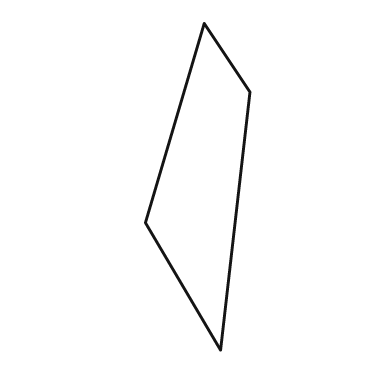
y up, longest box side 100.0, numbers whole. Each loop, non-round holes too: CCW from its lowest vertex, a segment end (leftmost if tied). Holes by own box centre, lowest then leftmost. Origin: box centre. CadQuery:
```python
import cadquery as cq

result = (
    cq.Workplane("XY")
    .moveTo(7.0, -50.0)
    .lineTo(16.0, 29.0)
    .lineTo(2.0, 50.0)
    .lineTo(-16.0, -11.0)
    .close()
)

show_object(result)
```